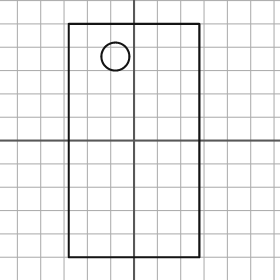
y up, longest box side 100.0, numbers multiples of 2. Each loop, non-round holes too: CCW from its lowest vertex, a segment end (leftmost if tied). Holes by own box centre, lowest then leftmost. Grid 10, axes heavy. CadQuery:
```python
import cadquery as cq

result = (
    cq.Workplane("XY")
    .moveTo(-28.0, -50.0)
    .lineTo(28.0, -50.0)
    .lineTo(28.0, 50.0)
    .lineTo(-28.0, 50.0)
    .close()
    .moveTo(-8.0, 36.0)
    .circle(6.0)
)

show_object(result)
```